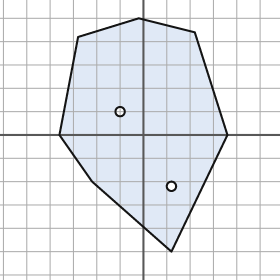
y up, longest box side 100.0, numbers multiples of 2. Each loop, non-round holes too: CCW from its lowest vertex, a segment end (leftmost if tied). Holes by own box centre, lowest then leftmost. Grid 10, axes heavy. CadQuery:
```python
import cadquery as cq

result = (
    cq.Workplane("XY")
    .moveTo(12.0, -50.0)
    .lineTo(36.0, 0.0)
    .lineTo(22.0, 44.0)
    .lineTo(-2.0, 50.0)
    .lineTo(-28.0, 42.0)
    .lineTo(-36.0, 0.0)
    .lineTo(-22.0, -20.0)
    .close()
    .moveTo(12.0, -22.0)
    .circle(2.0)
    .moveTo(-10.0, 10.0)
    .circle(2.0)
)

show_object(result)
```